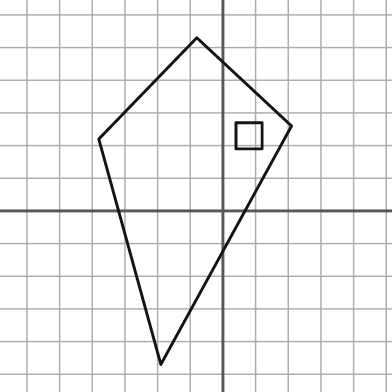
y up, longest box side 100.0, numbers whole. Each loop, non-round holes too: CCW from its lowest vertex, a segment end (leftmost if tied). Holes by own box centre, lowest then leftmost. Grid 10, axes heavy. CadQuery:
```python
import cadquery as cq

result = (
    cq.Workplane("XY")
    .moveTo(-19.0, -47.0)
    .lineTo(21.0, 26.0)
    .lineTo(-8.0, 53.0)
    .lineTo(-38.0, 22.0)
    .close()
    .moveTo(4.0, 19.0)
    .lineTo(12.0, 19.0)
    .lineTo(12.0, 27.0)
    .lineTo(4.0, 27.0)
    .close()
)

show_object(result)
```